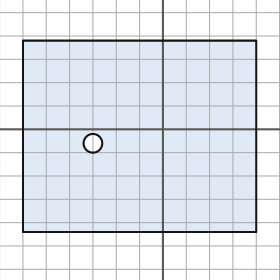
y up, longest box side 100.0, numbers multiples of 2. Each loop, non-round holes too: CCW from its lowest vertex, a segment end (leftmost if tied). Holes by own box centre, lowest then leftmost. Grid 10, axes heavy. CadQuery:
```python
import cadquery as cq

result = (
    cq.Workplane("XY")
    .moveTo(-60.0, -44.0)
    .lineTo(40.0, -44.0)
    .lineTo(40.0, 38.0)
    .lineTo(-60.0, 38.0)
    .close()
    .moveTo(-30.0, -6.0)
    .circle(4.0)
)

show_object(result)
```